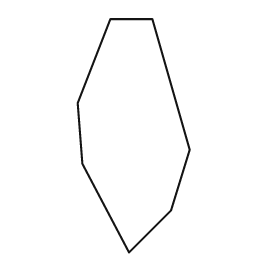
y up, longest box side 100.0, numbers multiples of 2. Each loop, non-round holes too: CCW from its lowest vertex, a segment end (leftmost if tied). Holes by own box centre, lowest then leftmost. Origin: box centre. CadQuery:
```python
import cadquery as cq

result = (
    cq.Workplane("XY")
    .moveTo(-2.0, -50.0)
    .lineTo(16.0, -32.0)
    .lineTo(24.0, -6.0)
    .lineTo(8.0, 50.0)
    .lineTo(-10.0, 50.0)
    .lineTo(-24.0, 14.0)
    .lineTo(-22.0, -12.0)
    .close()
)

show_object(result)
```